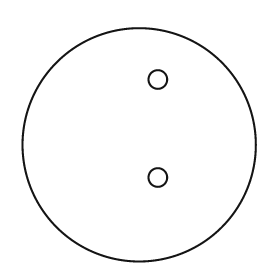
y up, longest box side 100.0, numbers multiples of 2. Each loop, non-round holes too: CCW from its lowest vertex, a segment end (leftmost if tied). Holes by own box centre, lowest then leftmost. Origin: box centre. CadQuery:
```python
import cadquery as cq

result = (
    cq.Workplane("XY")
    .moveTo(0.0, 0.0)
    .circle(50.0)
    .moveTo(8.0, -14.0)
    .circle(4.0)
    .moveTo(8.0, 28.0)
    .circle(4.0)
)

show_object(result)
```